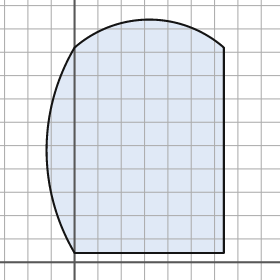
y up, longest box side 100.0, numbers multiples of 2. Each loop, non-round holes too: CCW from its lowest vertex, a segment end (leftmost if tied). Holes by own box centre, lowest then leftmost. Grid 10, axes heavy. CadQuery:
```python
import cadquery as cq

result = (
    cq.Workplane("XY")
    .moveTo(0.0, 4.0)
    .lineTo(64.0, 4.0)
    .lineTo(64.0, 92.0)
    .threePointArc((32.0, 104.0), (0.0, 92.0))
    .threePointArc((-12.0, 48.0), (0.0, 4.0))
    .close()
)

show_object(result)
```